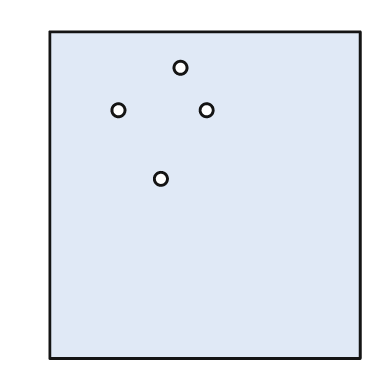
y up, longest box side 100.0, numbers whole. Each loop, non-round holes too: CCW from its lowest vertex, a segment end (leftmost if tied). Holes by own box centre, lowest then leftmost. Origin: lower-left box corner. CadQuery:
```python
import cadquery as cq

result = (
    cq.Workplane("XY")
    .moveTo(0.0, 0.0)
    .lineTo(95.0, 0.0)
    .lineTo(95.0, 100.0)
    .lineTo(0.0, 100.0)
    .close()
    .moveTo(34.0, 55.0)
    .circle(2.0)
    .moveTo(21.0, 76.0)
    .circle(2.0)
    .moveTo(48.0, 76.0)
    .circle(2.0)
    .moveTo(40.0, 89.0)
    .circle(2.0)
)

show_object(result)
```